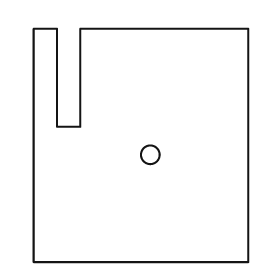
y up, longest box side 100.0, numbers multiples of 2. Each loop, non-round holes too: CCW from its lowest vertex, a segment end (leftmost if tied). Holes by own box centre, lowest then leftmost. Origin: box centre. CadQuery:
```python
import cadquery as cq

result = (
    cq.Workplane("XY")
    .moveTo(-46.0, -50.0)
    .lineTo(46.0, -50.0)
    .lineTo(46.0, 50.0)
    .lineTo(-26.0, 50.0)
    .lineTo(-26.0, 8.0)
    .lineTo(-36.0, 8.0)
    .lineTo(-36.0, 50.0)
    .lineTo(-46.0, 50.0)
    .close()
    .moveTo(4.0, -4.0)
    .circle(4.0)
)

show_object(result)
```